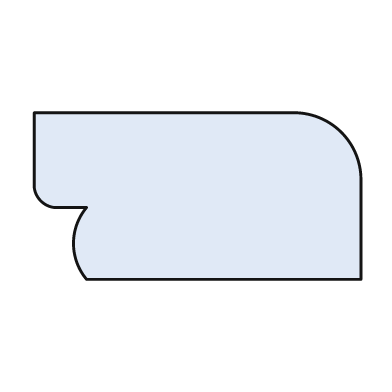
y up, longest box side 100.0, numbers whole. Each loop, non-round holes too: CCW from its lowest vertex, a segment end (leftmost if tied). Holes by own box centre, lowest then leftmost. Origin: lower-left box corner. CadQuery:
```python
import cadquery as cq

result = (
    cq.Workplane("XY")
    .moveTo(16.0, 0.0)
    .lineTo(100.0, 0.0)
    .lineTo(100.0, 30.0)
    .threePointArc((94.0, 45.0), (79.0, 51.0))
    .lineTo(0.0, 51.0)
    .lineTo(0.0, 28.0)
    .threePointArc((2.0, 24.0), (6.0, 22.0))
    .lineTo(16.0, 22.0)
    .threePointArc((12.0, 11.0), (16.0, 0.0))
    .close()
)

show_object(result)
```